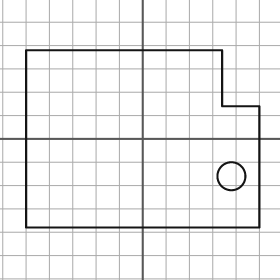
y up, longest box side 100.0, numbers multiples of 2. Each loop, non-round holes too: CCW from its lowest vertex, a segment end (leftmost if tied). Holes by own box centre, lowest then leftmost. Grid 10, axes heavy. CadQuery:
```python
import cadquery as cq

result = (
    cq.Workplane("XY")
    .moveTo(-50.0, -38.0)
    .lineTo(50.0, -38.0)
    .lineTo(50.0, 14.0)
    .lineTo(34.0, 14.0)
    .lineTo(34.0, 38.0)
    .lineTo(-50.0, 38.0)
    .close()
    .moveTo(38.0, -16.0)
    .circle(6.0)
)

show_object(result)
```